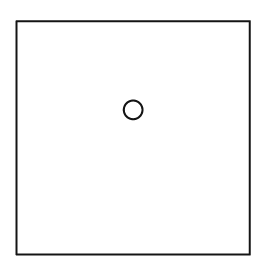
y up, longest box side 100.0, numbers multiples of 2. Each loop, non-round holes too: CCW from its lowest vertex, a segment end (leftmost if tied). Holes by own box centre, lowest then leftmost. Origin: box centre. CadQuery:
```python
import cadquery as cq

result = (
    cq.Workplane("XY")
    .moveTo(-50.0, -50.0)
    .lineTo(50.0, -50.0)
    .lineTo(50.0, 50.0)
    .lineTo(-50.0, 50.0)
    .close()
    .moveTo(0.0, 12.0)
    .circle(4.0)
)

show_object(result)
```